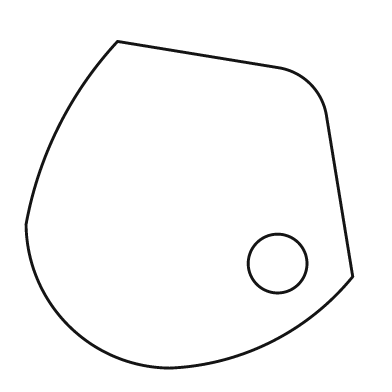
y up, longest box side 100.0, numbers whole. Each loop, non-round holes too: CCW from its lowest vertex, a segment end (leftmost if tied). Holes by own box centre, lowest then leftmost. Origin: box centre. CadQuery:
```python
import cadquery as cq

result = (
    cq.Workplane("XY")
    .moveTo(-6.0, -50.0)
    .threePointArc((25.0, -42.0), (50.0, -22.0))
    .lineTo(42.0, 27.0)
    .threePointArc((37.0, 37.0), (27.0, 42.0))
    .lineTo(-22.0, 50.0)
    .threePointArc((-40.0, 24.0), (-50.0, -6.0))
    .threePointArc((-37.0, -37.0), (-6.0, -50.0))
    .close()
    .moveTo(27.0, -18.0)
    .circle(9.0)
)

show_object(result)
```